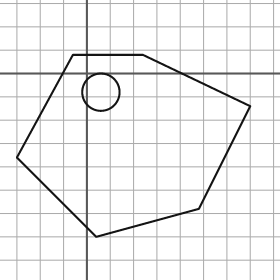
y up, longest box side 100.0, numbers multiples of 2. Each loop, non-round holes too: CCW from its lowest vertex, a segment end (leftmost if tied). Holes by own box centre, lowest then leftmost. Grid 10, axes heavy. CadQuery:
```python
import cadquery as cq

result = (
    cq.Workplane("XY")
    .moveTo(4.0, -70.0)
    .lineTo(48.0, -58.0)
    .lineTo(70.0, -14.0)
    .lineTo(24.0, 8.0)
    .lineTo(-6.0, 8.0)
    .lineTo(-30.0, -36.0)
    .close()
    .moveTo(6.0, -8.0)
    .circle(8.0)
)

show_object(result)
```